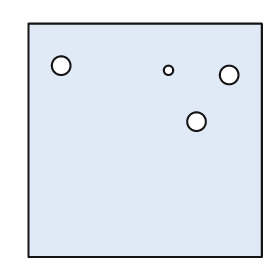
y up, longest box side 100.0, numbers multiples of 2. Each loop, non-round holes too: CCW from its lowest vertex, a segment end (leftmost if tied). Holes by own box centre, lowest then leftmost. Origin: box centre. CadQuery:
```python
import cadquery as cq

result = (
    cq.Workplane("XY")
    .moveTo(-50.0, -50.0)
    .lineTo(50.0, -50.0)
    .lineTo(50.0, 50.0)
    .lineTo(-50.0, 50.0)
    .close()
    .moveTo(22.0, 8.0)
    .circle(4.0)
    .moveTo(36.0, 28.0)
    .circle(4.0)
    .moveTo(10.0, 30.0)
    .circle(2.0)
    .moveTo(-36.0, 32.0)
    .circle(4.0)
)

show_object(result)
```